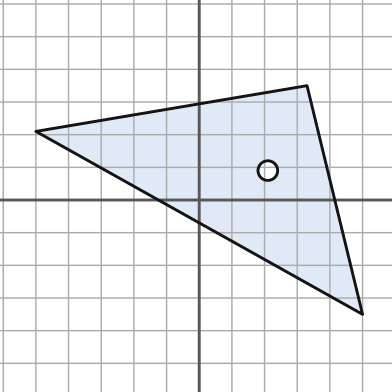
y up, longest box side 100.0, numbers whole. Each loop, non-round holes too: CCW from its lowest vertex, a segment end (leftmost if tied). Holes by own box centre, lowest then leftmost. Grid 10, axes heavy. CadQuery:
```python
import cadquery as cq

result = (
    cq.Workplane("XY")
    .moveTo(50.0, -35.0)
    .lineTo(33.0, 35.0)
    .lineTo(-50.0, 21.0)
    .close()
    .moveTo(21.0, 9.0)
    .circle(3.0)
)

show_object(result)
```